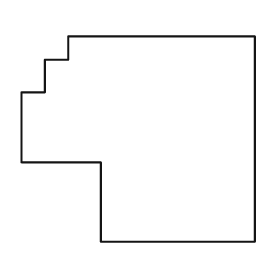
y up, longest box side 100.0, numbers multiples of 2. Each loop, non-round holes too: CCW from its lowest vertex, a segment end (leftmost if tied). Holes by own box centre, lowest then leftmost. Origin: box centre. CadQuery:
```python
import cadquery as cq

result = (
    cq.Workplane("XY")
    .moveTo(-16.0, -44.0)
    .lineTo(50.0, -44.0)
    .lineTo(50.0, 44.0)
    .lineTo(-30.0, 44.0)
    .lineTo(-30.0, 34.0)
    .lineTo(-40.0, 34.0)
    .lineTo(-40.0, 20.0)
    .lineTo(-50.0, 20.0)
    .lineTo(-50.0, -10.0)
    .lineTo(-16.0, -10.0)
    .close()
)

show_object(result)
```